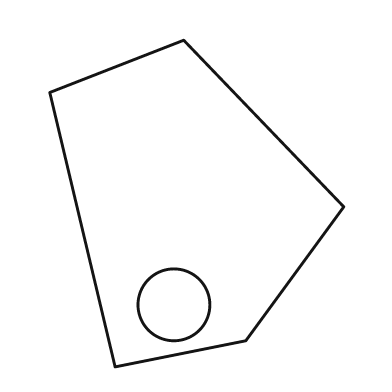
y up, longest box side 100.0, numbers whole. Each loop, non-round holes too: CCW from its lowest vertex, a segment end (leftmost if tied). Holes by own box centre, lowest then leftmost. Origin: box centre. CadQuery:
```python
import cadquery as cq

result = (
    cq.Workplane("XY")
    .moveTo(-25.0, -50.0)
    .lineTo(15.0, -42.0)
    .lineTo(45.0, -1.0)
    .lineTo(-4.0, 50.0)
    .lineTo(-45.0, 34.0)
    .close()
    .moveTo(-7.0, -31.0)
    .circle(11.0)
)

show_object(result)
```